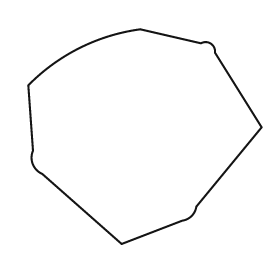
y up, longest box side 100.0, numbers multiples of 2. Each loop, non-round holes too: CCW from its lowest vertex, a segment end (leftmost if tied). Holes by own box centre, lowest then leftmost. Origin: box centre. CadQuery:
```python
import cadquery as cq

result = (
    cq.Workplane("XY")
    .moveTo(-10.0, -46.0)
    .lineTo(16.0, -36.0)
    .threePointArc((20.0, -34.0), (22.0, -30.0))
    .lineTo(50.0, 4.0)
    .lineTo(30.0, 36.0)
    .threePointArc((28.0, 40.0), (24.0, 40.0))
    .lineTo(-2.0, 46.0)
    .threePointArc((-28.0, 38.0), (-50.0, 22.0))
    .lineTo(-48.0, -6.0)
    .threePointArc((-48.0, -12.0), (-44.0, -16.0))
    .close()
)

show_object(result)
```